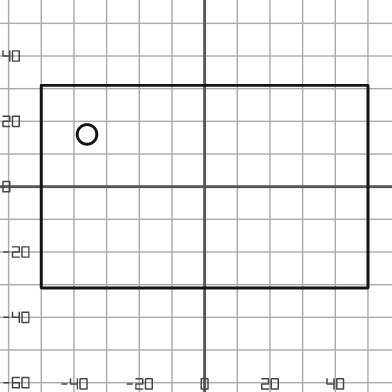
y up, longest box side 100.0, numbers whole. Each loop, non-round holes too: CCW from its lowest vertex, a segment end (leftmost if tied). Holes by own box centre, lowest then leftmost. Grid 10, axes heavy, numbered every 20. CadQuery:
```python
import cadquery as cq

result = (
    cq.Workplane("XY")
    .moveTo(-50.0, -31.0)
    .lineTo(50.0, -31.0)
    .lineTo(50.0, 31.0)
    .lineTo(-50.0, 31.0)
    .close()
    .moveTo(-36.0, 16.0)
    .circle(3.0)
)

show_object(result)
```